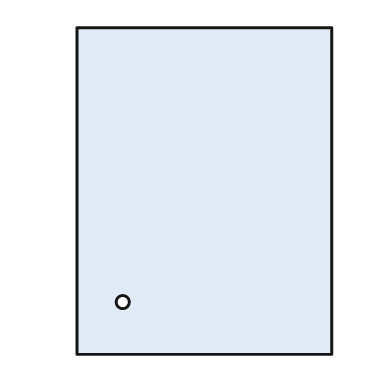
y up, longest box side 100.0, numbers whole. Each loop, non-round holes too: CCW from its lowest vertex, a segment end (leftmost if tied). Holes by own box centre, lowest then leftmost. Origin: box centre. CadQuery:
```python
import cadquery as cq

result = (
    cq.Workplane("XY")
    .moveTo(-39.0, -50.0)
    .lineTo(39.0, -50.0)
    .lineTo(39.0, 50.0)
    .lineTo(-39.0, 50.0)
    .close()
    .moveTo(-25.0, -34.0)
    .circle(2.0)
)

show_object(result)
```